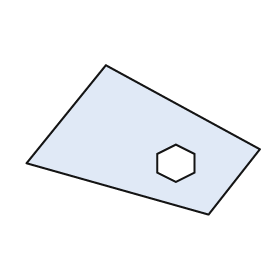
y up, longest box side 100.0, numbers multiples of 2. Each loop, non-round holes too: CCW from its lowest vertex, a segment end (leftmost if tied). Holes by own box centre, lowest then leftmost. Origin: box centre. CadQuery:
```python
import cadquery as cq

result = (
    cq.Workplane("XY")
    .moveTo(28.0, -32.0)
    .lineTo(50.0, -4.0)
    .lineTo(-16.0, 32.0)
    .lineTo(-50.0, -10.0)
    .close()
    .moveTo(14.0, -18.0)
    .lineTo(22.0, -14.0)
    .lineTo(22.0, -6.0)
    .lineTo(14.0, -2.0)
    .lineTo(6.0, -6.0)
    .lineTo(6.0, -14.0)
    .close()
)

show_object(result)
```